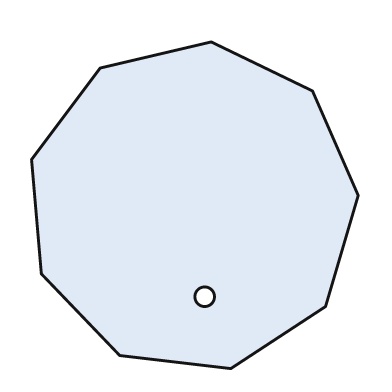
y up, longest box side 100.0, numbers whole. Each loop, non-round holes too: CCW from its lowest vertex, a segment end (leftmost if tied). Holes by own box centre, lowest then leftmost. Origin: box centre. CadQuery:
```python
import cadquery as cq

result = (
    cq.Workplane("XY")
    .moveTo(11.0, -50.0)
    .lineTo(40.0, -31.0)
    .lineTo(50.0, 3.0)
    .lineTo(36.0, 35.0)
    .lineTo(5.0, 50.0)
    .lineTo(-29.0, 42.0)
    .lineTo(-50.0, 14.0)
    .lineTo(-47.0, -21.0)
    .lineTo(-23.0, -46.0)
    .close()
    .moveTo(3.0, -28.0)
    .circle(3.0)
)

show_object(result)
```